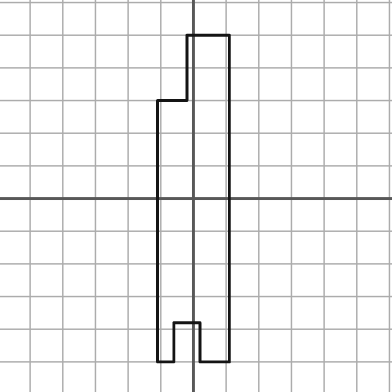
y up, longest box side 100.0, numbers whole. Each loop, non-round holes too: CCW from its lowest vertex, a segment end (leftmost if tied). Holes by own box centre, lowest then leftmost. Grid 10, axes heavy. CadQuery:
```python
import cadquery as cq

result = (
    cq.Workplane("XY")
    .moveTo(-11.0, -50.0)
    .lineTo(-6.0, -50.0)
    .lineTo(-6.0, -38.0)
    .lineTo(2.0, -38.0)
    .lineTo(2.0, -50.0)
    .lineTo(11.0, -50.0)
    .lineTo(11.0, 50.0)
    .lineTo(-2.0, 50.0)
    .lineTo(-2.0, 30.0)
    .lineTo(-11.0, 30.0)
    .close()
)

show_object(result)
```